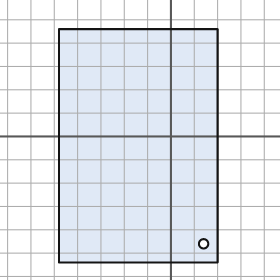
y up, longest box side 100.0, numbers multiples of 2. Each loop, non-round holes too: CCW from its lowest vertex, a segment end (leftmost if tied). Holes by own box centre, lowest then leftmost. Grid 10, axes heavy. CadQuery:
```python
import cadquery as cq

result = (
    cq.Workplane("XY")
    .moveTo(-48.0, -54.0)
    .lineTo(20.0, -54.0)
    .lineTo(20.0, 46.0)
    .lineTo(-48.0, 46.0)
    .close()
    .moveTo(14.0, -46.0)
    .circle(2.0)
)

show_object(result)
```